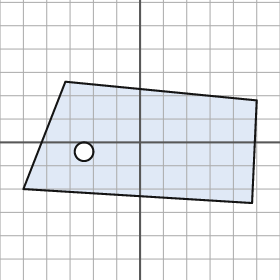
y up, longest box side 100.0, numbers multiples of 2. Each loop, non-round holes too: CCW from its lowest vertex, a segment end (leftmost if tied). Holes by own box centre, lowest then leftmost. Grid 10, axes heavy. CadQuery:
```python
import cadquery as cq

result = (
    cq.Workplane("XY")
    .moveTo(48.0, -26.0)
    .lineTo(50.0, 18.0)
    .lineTo(-32.0, 26.0)
    .lineTo(-50.0, -20.0)
    .close()
    .moveTo(-24.0, -4.0)
    .circle(4.0)
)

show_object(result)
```